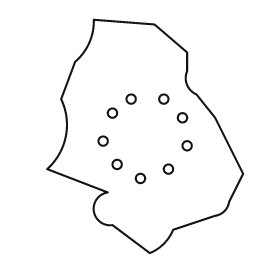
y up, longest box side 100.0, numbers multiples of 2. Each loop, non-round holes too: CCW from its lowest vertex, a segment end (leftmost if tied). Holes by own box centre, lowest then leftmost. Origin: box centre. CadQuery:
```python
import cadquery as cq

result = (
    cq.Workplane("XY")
    .moveTo(2.0, -50.0)
    .threePointArc((8.0, -46.0), (12.0, -40.0))
    .lineTo(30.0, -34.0)
    .threePointArc((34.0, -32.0), (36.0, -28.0))
    .lineTo(42.0, -16.0)
    .lineTo(30.0, 8.0)
    .lineTo(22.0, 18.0)
    .threePointArc((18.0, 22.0), (18.0, 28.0))
    .lineTo(18.0, 36.0)
    .lineTo(4.0, 48.0)
    .lineTo(-22.0, 50.0)
    .threePointArc((-24.0, 40.0), (-30.0, 32.0))
    .lineTo(-36.0, 16.0)
    .threePointArc((-34.0, 0.0), (-42.0, -14.0))
    .lineTo(-16.0, -24.0)
    .threePointArc((-22.0, -32.0), (-14.0, -38.0))
    .close()
    .moveTo(-2.0, -18.0)
    .circle(2.0)
    .moveTo(10.0, -14.0)
    .circle(2.0)
    .moveTo(-12.0, -12.0)
    .circle(2.0)
    .moveTo(18.0, -4.0)
    .circle(2.0)
    .moveTo(-18.0, -2.0)
    .circle(2.0)
    .moveTo(16.0, 8.0)
    .circle(2.0)
    .moveTo(-14.0, 10.0)
    .circle(2.0)
    .moveTo(-6.0, 16.0)
    .circle(2.0)
    .moveTo(8.0, 16.0)
    .circle(2.0)
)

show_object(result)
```